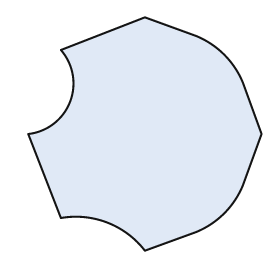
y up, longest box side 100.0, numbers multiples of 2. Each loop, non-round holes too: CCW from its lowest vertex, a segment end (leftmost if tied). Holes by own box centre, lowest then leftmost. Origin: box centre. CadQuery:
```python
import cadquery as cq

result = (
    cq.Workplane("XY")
    .moveTo(0.0, -50.0)
    .lineTo(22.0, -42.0)
    .threePointArc((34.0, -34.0), (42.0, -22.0))
    .lineTo(50.0, 0.0)
    .lineTo(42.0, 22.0)
    .threePointArc((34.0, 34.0), (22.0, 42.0))
    .lineTo(0.0, 50.0)
    .lineTo(-36.0, 36.0)
    .threePointArc((-32.0, 14.0), (-50.0, 0.0))
    .lineTo(-36.0, -36.0)
    .threePointArc((-16.0, -38.0), (0.0, -50.0))
    .close()
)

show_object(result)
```